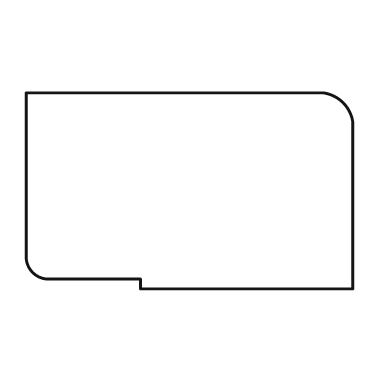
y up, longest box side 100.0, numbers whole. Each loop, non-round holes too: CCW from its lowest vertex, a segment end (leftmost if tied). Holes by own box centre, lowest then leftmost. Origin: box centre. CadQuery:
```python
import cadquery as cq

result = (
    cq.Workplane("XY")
    .moveTo(-15.0, -30.0)
    .lineTo(50.0, -30.0)
    .lineTo(50.0, 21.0)
    .threePointArc((47.0, 27.0), (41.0, 30.0))
    .lineTo(-50.0, 30.0)
    .lineTo(-50.0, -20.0)
    .threePointArc((-48.0, -25.0), (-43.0, -27.0))
    .lineTo(-15.0, -27.0)
    .close()
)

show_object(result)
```